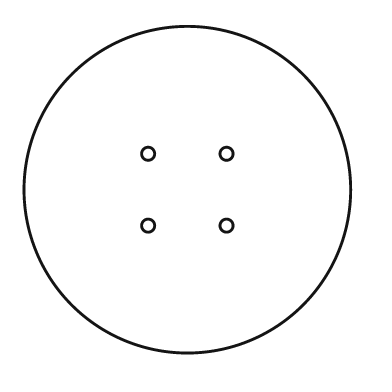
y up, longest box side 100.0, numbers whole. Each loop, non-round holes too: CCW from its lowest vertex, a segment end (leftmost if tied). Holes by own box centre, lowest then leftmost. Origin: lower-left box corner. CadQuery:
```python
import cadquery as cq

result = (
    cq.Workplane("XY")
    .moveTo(50.0, 50.0)
    .circle(50.0)
    .moveTo(38.0, 39.0)
    .circle(2.0)
    .moveTo(62.0, 39.0)
    .circle(2.0)
    .moveTo(38.0, 61.0)
    .circle(2.0)
    .moveTo(62.0, 61.0)
    .circle(2.0)
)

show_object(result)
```